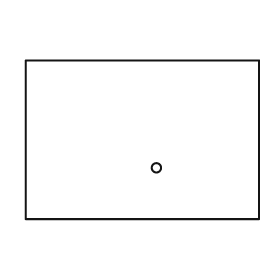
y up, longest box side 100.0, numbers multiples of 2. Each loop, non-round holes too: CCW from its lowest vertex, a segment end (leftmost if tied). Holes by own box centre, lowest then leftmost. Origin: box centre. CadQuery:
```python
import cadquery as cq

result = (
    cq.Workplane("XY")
    .moveTo(-50.0, -34.0)
    .lineTo(50.0, -34.0)
    .lineTo(50.0, 34.0)
    .lineTo(-50.0, 34.0)
    .close()
    .moveTo(6.0, -12.0)
    .circle(2.0)
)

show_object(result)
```